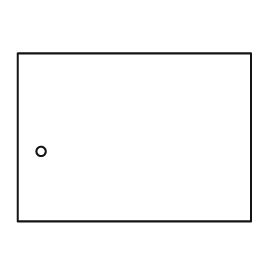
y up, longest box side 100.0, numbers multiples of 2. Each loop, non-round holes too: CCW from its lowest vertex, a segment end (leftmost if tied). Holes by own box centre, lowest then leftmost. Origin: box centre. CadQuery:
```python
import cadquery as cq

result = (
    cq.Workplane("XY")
    .moveTo(-50.0, -36.0)
    .lineTo(50.0, -36.0)
    .lineTo(50.0, 36.0)
    .lineTo(-50.0, 36.0)
    .close()
    .moveTo(-40.0, -6.0)
    .circle(2.0)
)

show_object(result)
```